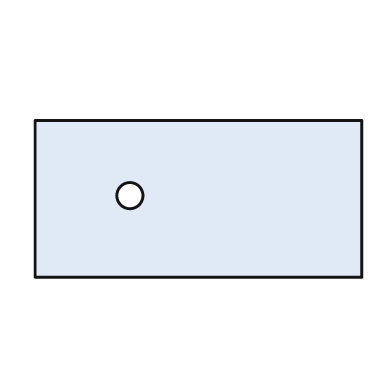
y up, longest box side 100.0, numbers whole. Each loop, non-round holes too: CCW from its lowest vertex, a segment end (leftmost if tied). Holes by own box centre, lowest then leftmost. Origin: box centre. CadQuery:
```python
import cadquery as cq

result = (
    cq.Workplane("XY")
    .moveTo(-50.0, -24.0)
    .lineTo(50.0, -24.0)
    .lineTo(50.0, 24.0)
    .lineTo(-50.0, 24.0)
    .close()
    .moveTo(-21.0, 1.0)
    .circle(4.0)
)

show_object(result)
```